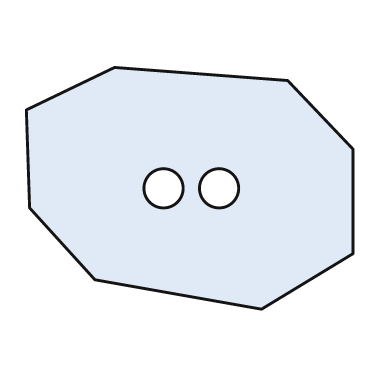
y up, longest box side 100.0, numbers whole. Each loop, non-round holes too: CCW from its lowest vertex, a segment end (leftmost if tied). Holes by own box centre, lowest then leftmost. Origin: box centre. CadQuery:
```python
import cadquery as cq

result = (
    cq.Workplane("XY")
    .moveTo(22.0, -37.0)
    .lineTo(50.0, -20.0)
    .lineTo(50.0, 12.0)
    .lineTo(30.0, 33.0)
    .lineTo(-23.0, 37.0)
    .lineTo(-50.0, 24.0)
    .lineTo(-49.0, -6.0)
    .lineTo(-29.0, -28.0)
    .close()
    .moveTo(-8.0, 0.0)
    .circle(6.0)
    .moveTo(9.0, 0.0)
    .circle(6.0)
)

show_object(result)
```